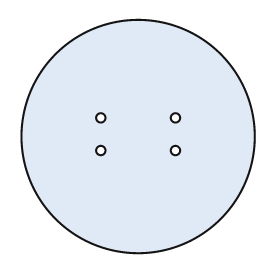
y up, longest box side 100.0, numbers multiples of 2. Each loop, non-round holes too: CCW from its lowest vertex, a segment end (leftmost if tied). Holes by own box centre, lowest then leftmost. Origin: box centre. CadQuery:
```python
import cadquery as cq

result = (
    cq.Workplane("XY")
    .moveTo(0.0, 0.0)
    .circle(50.0)
    .moveTo(-16.0, -6.0)
    .circle(2.0)
    .moveTo(16.0, -6.0)
    .circle(2.0)
    .moveTo(-16.0, 8.0)
    .circle(2.0)
    .moveTo(16.0, 8.0)
    .circle(2.0)
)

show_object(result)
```